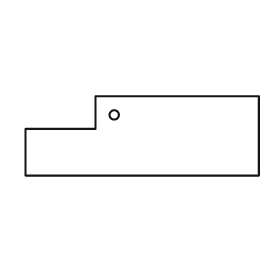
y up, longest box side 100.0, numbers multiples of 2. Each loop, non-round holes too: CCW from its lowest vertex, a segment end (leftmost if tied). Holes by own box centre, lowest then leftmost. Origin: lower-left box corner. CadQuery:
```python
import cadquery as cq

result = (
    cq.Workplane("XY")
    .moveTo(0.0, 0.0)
    .lineTo(100.0, 0.0)
    .lineTo(100.0, 34.0)
    .lineTo(30.0, 34.0)
    .lineTo(30.0, 20.0)
    .lineTo(0.0, 20.0)
    .close()
    .moveTo(38.0, 26.0)
    .circle(2.0)
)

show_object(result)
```